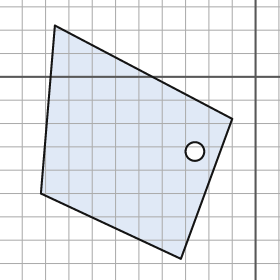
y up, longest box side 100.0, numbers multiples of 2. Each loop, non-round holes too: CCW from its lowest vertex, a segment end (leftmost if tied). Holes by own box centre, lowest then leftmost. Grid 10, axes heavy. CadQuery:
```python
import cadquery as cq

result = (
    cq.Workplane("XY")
    .moveTo(-32.0, -78.0)
    .lineTo(-10.0, -18.0)
    .lineTo(-86.0, 22.0)
    .lineTo(-92.0, -50.0)
    .close()
    .moveTo(-26.0, -32.0)
    .circle(4.0)
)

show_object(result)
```